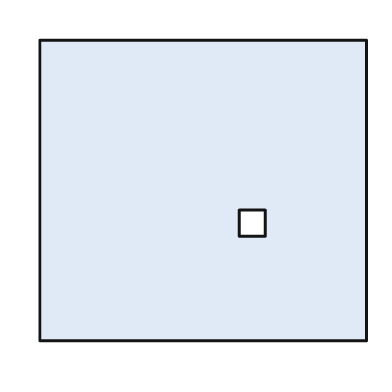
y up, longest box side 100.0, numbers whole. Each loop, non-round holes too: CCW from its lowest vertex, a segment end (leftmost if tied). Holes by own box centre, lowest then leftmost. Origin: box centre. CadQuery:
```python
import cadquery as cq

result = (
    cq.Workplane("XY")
    .moveTo(-50.0, -46.0)
    .lineTo(50.0, -46.0)
    .lineTo(50.0, 46.0)
    .lineTo(-50.0, 46.0)
    .close()
    .moveTo(11.0, -14.0)
    .lineTo(19.0, -14.0)
    .lineTo(19.0, -6.0)
    .lineTo(11.0, -6.0)
    .close()
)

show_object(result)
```